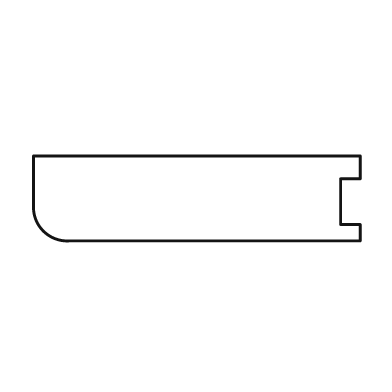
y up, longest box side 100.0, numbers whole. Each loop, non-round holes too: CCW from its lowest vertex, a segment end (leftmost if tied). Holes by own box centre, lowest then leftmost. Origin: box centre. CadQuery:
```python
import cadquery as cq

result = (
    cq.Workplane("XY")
    .moveTo(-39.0, -13.0)
    .lineTo(50.0, -13.0)
    .lineTo(50.0, -8.0)
    .lineTo(44.0, -8.0)
    .lineTo(44.0, 6.0)
    .lineTo(50.0, 6.0)
    .lineTo(50.0, 13.0)
    .lineTo(-50.0, 13.0)
    .lineTo(-50.0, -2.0)
    .threePointArc((-47.0, -10.0), (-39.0, -13.0))
    .close()
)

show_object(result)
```